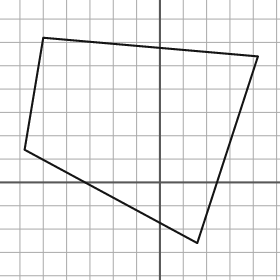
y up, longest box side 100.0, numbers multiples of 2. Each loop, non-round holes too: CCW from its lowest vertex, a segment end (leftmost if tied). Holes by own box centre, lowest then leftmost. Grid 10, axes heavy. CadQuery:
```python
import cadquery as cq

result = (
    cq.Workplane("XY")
    .moveTo(16.0, -26.0)
    .lineTo(42.0, 54.0)
    .lineTo(-50.0, 62.0)
    .lineTo(-58.0, 14.0)
    .close()
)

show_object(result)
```